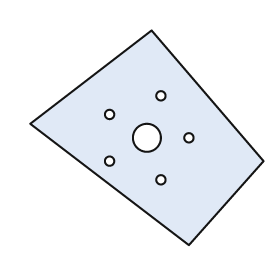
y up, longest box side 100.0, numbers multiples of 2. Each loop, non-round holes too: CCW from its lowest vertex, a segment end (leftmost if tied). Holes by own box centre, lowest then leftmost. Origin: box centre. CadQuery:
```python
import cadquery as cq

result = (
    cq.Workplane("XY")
    .moveTo(18.0, -46.0)
    .lineTo(50.0, -10.0)
    .lineTo(2.0, 46.0)
    .lineTo(-50.0, 6.0)
    .close()
    .moveTo(6.0, -18.0)
    .circle(2.0)
    .moveTo(-16.0, -10.0)
    .circle(2.0)
    .moveTo(0.0, 0.0)
    .circle(6.0)
    .moveTo(18.0, 0.0)
    .circle(2.0)
    .moveTo(-16.0, 10.0)
    .circle(2.0)
    .moveTo(6.0, 18.0)
    .circle(2.0)
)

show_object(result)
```